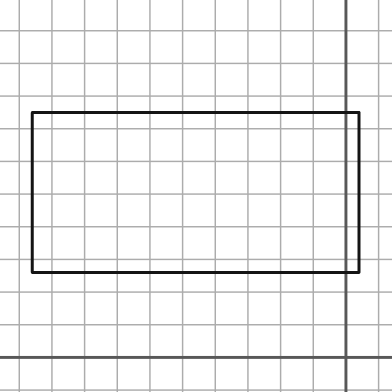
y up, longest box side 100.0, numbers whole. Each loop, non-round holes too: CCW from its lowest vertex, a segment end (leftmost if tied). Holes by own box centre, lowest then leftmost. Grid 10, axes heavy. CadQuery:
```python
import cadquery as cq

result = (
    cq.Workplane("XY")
    .moveTo(-96.0, 26.0)
    .lineTo(4.0, 26.0)
    .lineTo(4.0, 75.0)
    .lineTo(-96.0, 75.0)
    .close()
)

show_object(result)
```